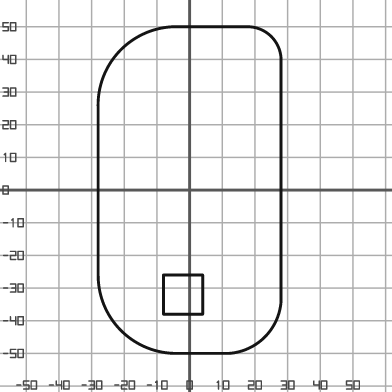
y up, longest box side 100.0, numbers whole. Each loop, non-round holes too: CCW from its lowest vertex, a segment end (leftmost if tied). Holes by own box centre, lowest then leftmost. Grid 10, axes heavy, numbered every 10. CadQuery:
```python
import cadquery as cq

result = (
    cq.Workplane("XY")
    .moveTo(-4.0, -50.0)
    .lineTo(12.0, -50.0)
    .threePointArc((23.0, -45.0), (28.0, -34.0))
    .lineTo(28.0, 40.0)
    .threePointArc((25.0, 47.0), (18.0, 50.0))
    .lineTo(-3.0, 50.0)
    .threePointArc((-21.0, 43.0), (-28.0, 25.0))
    .lineTo(-28.0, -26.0)
    .threePointArc((-21.0, -43.0), (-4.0, -50.0))
    .close()
    .moveTo(-8.0, -38.0)
    .lineTo(4.0, -38.0)
    .lineTo(4.0, -26.0)
    .lineTo(-8.0, -26.0)
    .close()
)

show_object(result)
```